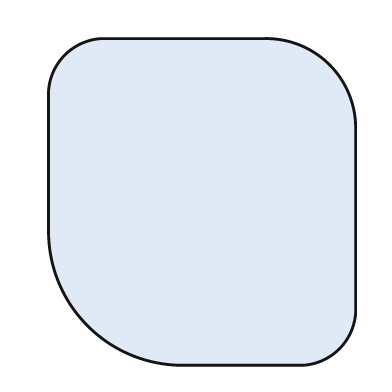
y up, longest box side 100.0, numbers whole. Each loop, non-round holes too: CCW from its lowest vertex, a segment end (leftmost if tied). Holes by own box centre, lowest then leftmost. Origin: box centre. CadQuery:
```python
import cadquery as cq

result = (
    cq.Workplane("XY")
    .moveTo(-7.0, -50.0)
    .lineTo(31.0, -50.0)
    .threePointArc((42.0, -45.0), (47.0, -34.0))
    .lineTo(47.0, 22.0)
    .threePointArc((39.0, 42.0), (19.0, 50.0))
    .lineTo(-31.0, 50.0)
    .threePointArc((-42.0, 45.0), (-47.0, 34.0))
    .lineTo(-47.0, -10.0)
    .threePointArc((-35.0, -38.0), (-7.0, -50.0))
    .close()
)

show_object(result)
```